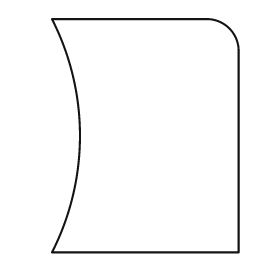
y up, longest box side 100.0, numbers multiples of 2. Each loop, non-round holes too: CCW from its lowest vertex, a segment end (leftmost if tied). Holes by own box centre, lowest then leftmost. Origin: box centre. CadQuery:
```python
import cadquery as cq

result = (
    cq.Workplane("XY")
    .moveTo(-40.0, -50.0)
    .lineTo(40.0, -50.0)
    .lineTo(40.0, 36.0)
    .threePointArc((36.0, 46.0), (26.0, 50.0))
    .lineTo(-40.0, 50.0)
    .threePointArc((-28.0, 0.0), (-40.0, -50.0))
    .close()
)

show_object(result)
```